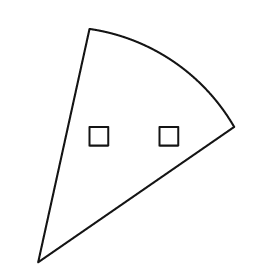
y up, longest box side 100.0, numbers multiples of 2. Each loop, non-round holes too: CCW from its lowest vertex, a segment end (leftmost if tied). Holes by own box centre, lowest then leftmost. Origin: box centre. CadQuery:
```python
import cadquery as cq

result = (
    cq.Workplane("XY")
    .moveTo(-42.0, -50.0)
    .lineTo(42.0, 8.0)
    .threePointArc((16.0, 36.0), (-20.0, 50.0))
    .close()
    .moveTo(-20.0, 0.0)
    .lineTo(-12.0, 0.0)
    .lineTo(-12.0, 8.0)
    .lineTo(-20.0, 8.0)
    .close()
    .moveTo(10.0, 0.0)
    .lineTo(18.0, 0.0)
    .lineTo(18.0, 8.0)
    .lineTo(10.0, 8.0)
    .close()
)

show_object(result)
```